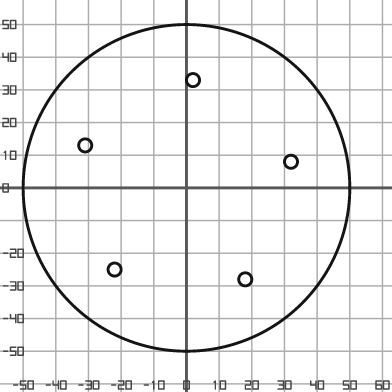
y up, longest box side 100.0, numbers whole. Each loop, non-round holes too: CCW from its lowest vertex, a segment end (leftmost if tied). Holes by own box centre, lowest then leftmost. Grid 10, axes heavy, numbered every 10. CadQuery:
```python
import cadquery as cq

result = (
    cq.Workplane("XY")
    .moveTo(0.0, 0.0)
    .circle(50.0)
    .moveTo(18.0, -28.0)
    .circle(2.0)
    .moveTo(-22.0, -25.0)
    .circle(2.0)
    .moveTo(32.0, 8.0)
    .circle(2.0)
    .moveTo(-31.0, 13.0)
    .circle(2.0)
    .moveTo(2.0, 33.0)
    .circle(2.0)
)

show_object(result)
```